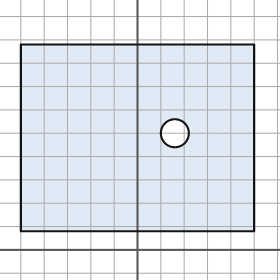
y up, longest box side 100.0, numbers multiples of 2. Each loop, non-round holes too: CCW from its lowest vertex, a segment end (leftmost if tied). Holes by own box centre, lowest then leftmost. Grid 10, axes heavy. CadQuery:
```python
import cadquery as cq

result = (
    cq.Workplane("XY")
    .moveTo(-50.0, 8.0)
    .lineTo(50.0, 8.0)
    .lineTo(50.0, 88.0)
    .lineTo(-50.0, 88.0)
    .close()
    .moveTo(16.0, 50.0)
    .circle(6.0)
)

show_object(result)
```